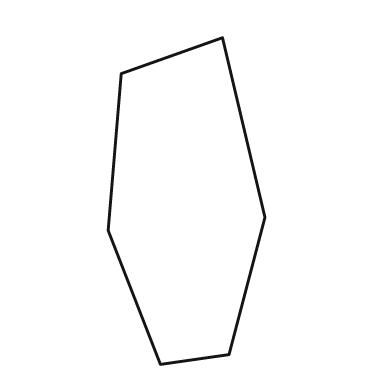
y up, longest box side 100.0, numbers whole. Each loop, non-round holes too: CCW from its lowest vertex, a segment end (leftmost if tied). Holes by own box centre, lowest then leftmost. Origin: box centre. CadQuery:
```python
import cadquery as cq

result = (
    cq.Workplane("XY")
    .moveTo(-8.0, -50.0)
    .lineTo(13.0, -47.0)
    .lineTo(24.0, -5.0)
    .lineTo(11.0, 50.0)
    .lineTo(-20.0, 39.0)
    .lineTo(-24.0, -9.0)
    .close()
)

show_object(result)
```